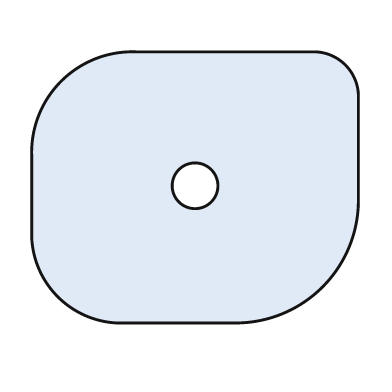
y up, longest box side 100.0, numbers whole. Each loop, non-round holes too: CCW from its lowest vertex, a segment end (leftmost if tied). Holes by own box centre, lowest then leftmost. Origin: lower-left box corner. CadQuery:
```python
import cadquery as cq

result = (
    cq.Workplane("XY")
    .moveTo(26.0, 0.0)
    .lineTo(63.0, 0.0)
    .threePointArc((89.0, 11.0), (100.0, 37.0))
    .lineTo(100.0, 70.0)
    .threePointArc((96.0, 79.0), (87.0, 83.0))
    .lineTo(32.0, 83.0)
    .threePointArc((9.0, 74.0), (0.0, 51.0))
    .lineTo(0.0, 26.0)
    .threePointArc((8.0, 8.0), (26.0, 0.0))
    .close()
    .moveTo(50.0, 42.0)
    .circle(7.0)
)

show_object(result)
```